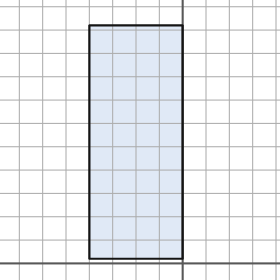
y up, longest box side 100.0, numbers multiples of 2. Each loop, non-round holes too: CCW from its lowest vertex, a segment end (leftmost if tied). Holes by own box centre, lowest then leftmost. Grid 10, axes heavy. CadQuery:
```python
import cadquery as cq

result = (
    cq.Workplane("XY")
    .moveTo(-40.0, 2.0)
    .lineTo(0.0, 2.0)
    .lineTo(0.0, 102.0)
    .lineTo(-40.0, 102.0)
    .close()
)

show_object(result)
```